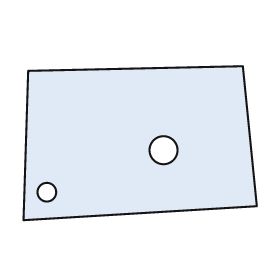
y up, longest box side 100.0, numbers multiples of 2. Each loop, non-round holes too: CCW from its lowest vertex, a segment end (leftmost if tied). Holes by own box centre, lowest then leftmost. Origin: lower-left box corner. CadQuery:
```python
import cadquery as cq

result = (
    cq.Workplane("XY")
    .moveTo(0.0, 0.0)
    .lineTo(100.0, 6.0)
    .lineTo(94.0, 66.0)
    .lineTo(2.0, 64.0)
    .close()
    .moveTo(10.0, 12.0)
    .circle(4.0)
    .moveTo(60.0, 30.0)
    .circle(6.0)
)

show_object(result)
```